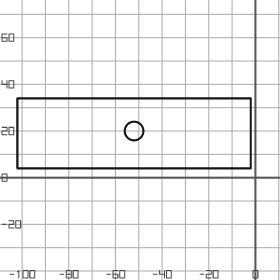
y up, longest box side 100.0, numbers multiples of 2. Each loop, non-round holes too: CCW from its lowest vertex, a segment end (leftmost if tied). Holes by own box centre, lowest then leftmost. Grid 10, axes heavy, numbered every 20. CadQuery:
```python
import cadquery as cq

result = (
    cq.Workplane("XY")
    .moveTo(-102.0, 4.0)
    .lineTo(-2.0, 4.0)
    .lineTo(-2.0, 34.0)
    .lineTo(-102.0, 34.0)
    .close()
    .moveTo(-52.0, 20.0)
    .circle(4.0)
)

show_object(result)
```